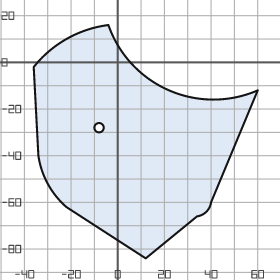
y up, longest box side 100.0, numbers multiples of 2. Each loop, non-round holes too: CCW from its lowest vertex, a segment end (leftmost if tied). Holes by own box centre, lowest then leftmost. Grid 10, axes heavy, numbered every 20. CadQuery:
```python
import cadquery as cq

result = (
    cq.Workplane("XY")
    .moveTo(12.0, -84.0)
    .lineTo(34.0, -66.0)
    .threePointArc((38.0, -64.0), (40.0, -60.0))
    .lineTo(60.0, -12.0)
    .threePointArc((22.0, -12.0), (-4.0, 16.0))
    .threePointArc((-22.0, 10.0), (-36.0, -2.0))
    .lineTo(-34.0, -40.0)
    .threePointArc((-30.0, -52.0), (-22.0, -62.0))
    .close()
    .moveTo(-8.0, -28.0)
    .circle(2.0)
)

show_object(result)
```